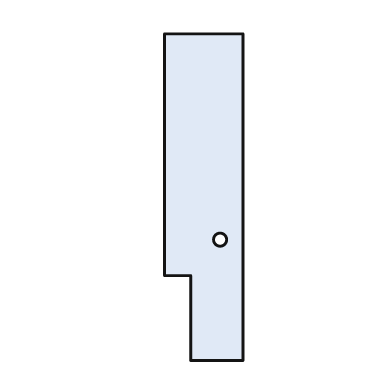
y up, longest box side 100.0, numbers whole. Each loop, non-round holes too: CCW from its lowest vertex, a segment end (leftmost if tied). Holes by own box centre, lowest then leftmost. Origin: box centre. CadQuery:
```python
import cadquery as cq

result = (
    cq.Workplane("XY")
    .moveTo(-4.0, -50.0)
    .lineTo(12.0, -50.0)
    .lineTo(12.0, 50.0)
    .lineTo(-12.0, 50.0)
    .lineTo(-12.0, -24.0)
    .lineTo(-4.0, -24.0)
    .close()
    .moveTo(5.0, -13.0)
    .circle(2.0)
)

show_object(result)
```